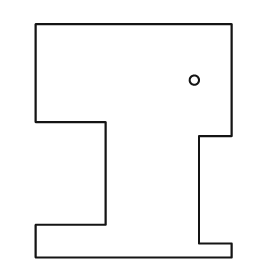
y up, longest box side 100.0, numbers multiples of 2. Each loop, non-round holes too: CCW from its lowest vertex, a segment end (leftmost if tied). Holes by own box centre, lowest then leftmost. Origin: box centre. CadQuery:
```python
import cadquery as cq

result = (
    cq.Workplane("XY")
    .moveTo(-42.0, -50.0)
    .lineTo(42.0, -50.0)
    .lineTo(42.0, -44.0)
    .lineTo(28.0, -44.0)
    .lineTo(28.0, 2.0)
    .lineTo(42.0, 2.0)
    .lineTo(42.0, 50.0)
    .lineTo(-42.0, 50.0)
    .lineTo(-42.0, 8.0)
    .lineTo(-12.0, 8.0)
    .lineTo(-12.0, -36.0)
    .lineTo(-42.0, -36.0)
    .close()
    .moveTo(26.0, 26.0)
    .circle(2.0)
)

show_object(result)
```